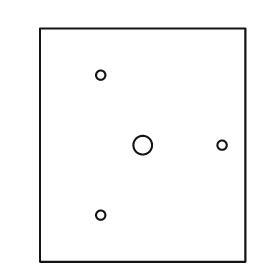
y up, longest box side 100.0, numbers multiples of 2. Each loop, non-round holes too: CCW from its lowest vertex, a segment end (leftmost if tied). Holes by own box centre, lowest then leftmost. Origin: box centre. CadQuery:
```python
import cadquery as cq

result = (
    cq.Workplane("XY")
    .moveTo(-44.0, -50.0)
    .lineTo(44.0, -50.0)
    .lineTo(44.0, 50.0)
    .lineTo(-44.0, 50.0)
    .close()
    .moveTo(-18.0, -30.0)
    .circle(2.0)
    .moveTo(0.0, 0.0)
    .circle(4.0)
    .moveTo(34.0, 0.0)
    .circle(2.0)
    .moveTo(-18.0, 30.0)
    .circle(2.0)
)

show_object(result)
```